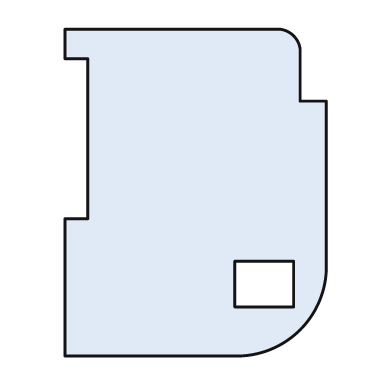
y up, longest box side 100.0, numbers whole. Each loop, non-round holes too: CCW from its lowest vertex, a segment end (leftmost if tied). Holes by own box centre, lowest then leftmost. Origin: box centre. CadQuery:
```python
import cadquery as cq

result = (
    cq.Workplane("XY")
    .moveTo(-40.0, -50.0)
    .lineTo(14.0, -50.0)
    .threePointArc((32.0, -42.0), (40.0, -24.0))
    .lineTo(40.0, 28.0)
    .lineTo(32.0, 28.0)
    .lineTo(32.0, 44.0)
    .threePointArc((30.0, 48.0), (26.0, 50.0))
    .lineTo(-40.0, 50.0)
    .lineTo(-40.0, 41.0)
    .lineTo(-33.0, 41.0)
    .lineTo(-33.0, -8.0)
    .lineTo(-40.0, -8.0)
    .close()
    .moveTo(12.0, -35.0)
    .lineTo(30.0, -35.0)
    .lineTo(30.0, -21.0)
    .lineTo(12.0, -21.0)
    .close()
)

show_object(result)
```